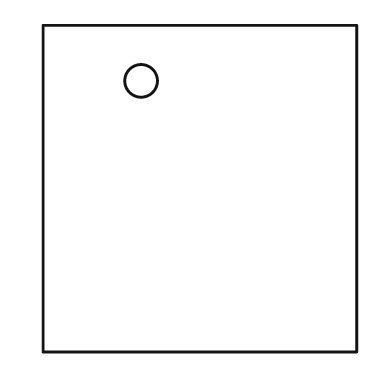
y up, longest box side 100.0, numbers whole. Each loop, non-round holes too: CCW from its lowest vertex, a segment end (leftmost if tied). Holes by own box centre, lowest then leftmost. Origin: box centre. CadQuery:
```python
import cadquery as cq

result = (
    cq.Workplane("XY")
    .moveTo(-48.0, -50.0)
    .lineTo(48.0, -50.0)
    .lineTo(48.0, 50.0)
    .lineTo(-48.0, 50.0)
    .close()
    .moveTo(-18.0, 33.0)
    .circle(5.0)
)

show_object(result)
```